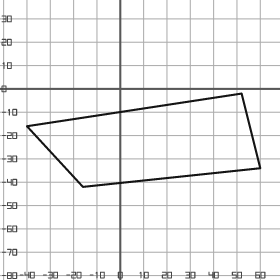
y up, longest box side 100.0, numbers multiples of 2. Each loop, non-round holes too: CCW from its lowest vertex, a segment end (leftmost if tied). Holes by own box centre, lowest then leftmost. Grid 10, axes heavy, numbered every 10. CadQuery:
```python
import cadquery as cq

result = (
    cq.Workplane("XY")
    .moveTo(-16.0, -42.0)
    .lineTo(60.0, -34.0)
    .lineTo(52.0, -2.0)
    .lineTo(-40.0, -16.0)
    .close()
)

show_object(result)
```